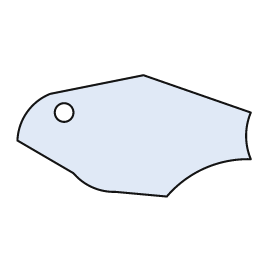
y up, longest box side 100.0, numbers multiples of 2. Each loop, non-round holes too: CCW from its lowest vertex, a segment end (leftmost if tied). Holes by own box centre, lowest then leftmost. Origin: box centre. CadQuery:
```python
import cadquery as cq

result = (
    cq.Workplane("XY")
    .moveTo(14.0, -26.0)
    .threePointArc((30.0, -14.0), (50.0, -10.0))
    .threePointArc((48.0, 0.0), (50.0, 10.0))
    .lineTo(4.0, 26.0)
    .lineTo(-36.0, 18.0)
    .threePointArc((-46.0, 10.0), (-50.0, -2.0))
    .lineTo(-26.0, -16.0)
    .threePointArc((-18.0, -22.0), (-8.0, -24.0))
    .close()
    .moveTo(-30.0, 10.0)
    .circle(4.0)
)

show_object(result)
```